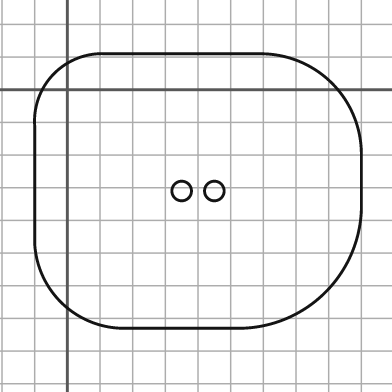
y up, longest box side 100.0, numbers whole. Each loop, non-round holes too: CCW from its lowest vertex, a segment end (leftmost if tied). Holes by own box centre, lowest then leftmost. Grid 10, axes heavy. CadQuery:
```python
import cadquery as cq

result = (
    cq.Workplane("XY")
    .moveTo(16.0, -73.0)
    .lineTo(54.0, -73.0)
    .threePointArc((79.0, -62.0), (90.0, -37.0))
    .lineTo(90.0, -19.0)
    .threePointArc((81.0, 2.0), (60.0, 11.0))
    .lineTo(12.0, 11.0)
    .threePointArc((-4.0, 5.0), (-10.0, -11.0))
    .lineTo(-10.0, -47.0)
    .threePointArc((-2.0, -65.0), (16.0, -73.0))
    .close()
    .moveTo(35.0, -31.0)
    .circle(3.0)
    .moveTo(45.0, -31.0)
    .circle(3.0)
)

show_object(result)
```